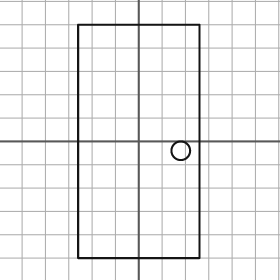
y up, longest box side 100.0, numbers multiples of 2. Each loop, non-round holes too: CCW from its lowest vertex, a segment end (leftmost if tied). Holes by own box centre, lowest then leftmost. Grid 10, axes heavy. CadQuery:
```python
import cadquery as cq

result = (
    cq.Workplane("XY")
    .moveTo(-26.0, -50.0)
    .lineTo(26.0, -50.0)
    .lineTo(26.0, 50.0)
    .lineTo(-26.0, 50.0)
    .close()
    .moveTo(18.0, -4.0)
    .circle(4.0)
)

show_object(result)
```